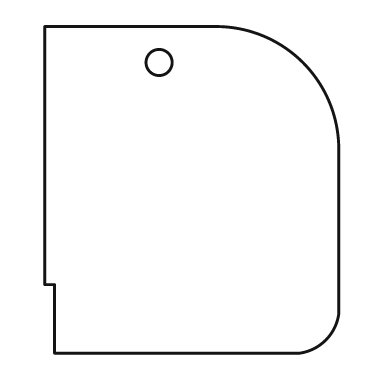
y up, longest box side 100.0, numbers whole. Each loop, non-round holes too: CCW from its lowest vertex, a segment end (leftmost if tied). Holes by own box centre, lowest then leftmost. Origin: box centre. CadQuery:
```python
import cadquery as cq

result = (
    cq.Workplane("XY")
    .moveTo(-42.0, -50.0)
    .lineTo(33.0, -50.0)
    .threePointArc((41.0, -46.0), (45.0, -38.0))
    .lineTo(45.0, 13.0)
    .threePointArc((34.0, 39.0), (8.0, 50.0))
    .lineTo(-45.0, 50.0)
    .lineTo(-45.0, -29.0)
    .lineTo(-42.0, -29.0)
    .close()
    .moveTo(-10.0, 39.0)
    .circle(4.0)
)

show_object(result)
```